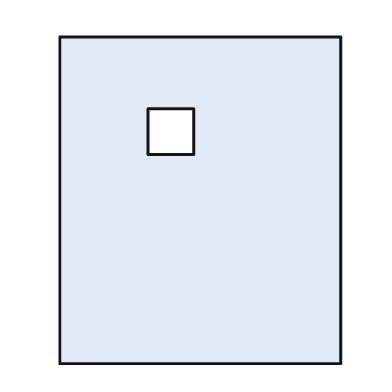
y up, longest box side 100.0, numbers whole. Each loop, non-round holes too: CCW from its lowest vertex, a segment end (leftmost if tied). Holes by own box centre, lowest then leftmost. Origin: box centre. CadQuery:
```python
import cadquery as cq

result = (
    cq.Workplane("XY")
    .moveTo(-43.0, -50.0)
    .lineTo(43.0, -50.0)
    .lineTo(43.0, 50.0)
    .lineTo(-43.0, 50.0)
    .close()
    .moveTo(-16.0, 14.0)
    .lineTo(-2.0, 14.0)
    .lineTo(-2.0, 28.0)
    .lineTo(-16.0, 28.0)
    .close()
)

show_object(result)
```